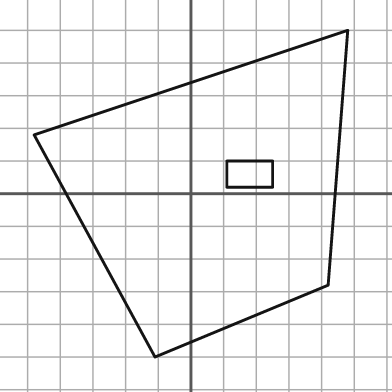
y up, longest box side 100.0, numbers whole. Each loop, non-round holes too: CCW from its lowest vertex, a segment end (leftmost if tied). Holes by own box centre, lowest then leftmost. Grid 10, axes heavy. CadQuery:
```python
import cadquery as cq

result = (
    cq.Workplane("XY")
    .moveTo(-11.0, -50.0)
    .lineTo(42.0, -28.0)
    .lineTo(48.0, 50.0)
    .lineTo(-48.0, 18.0)
    .close()
    .moveTo(11.0, 2.0)
    .lineTo(25.0, 2.0)
    .lineTo(25.0, 10.0)
    .lineTo(11.0, 10.0)
    .close()
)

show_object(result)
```